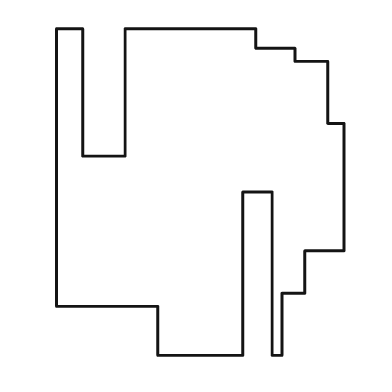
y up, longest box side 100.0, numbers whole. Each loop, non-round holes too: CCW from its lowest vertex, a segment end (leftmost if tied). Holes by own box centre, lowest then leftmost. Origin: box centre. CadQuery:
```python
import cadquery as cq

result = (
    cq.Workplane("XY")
    .moveTo(-13.0, -50.0)
    .lineTo(13.0, -50.0)
    .lineTo(13.0, 0.0)
    .lineTo(22.0, 0.0)
    .lineTo(22.0, -50.0)
    .lineTo(25.0, -50.0)
    .lineTo(25.0, -31.0)
    .lineTo(32.0, -31.0)
    .lineTo(32.0, -18.0)
    .lineTo(44.0, -18.0)
    .lineTo(44.0, 21.0)
    .lineTo(39.0, 21.0)
    .lineTo(39.0, 40.0)
    .lineTo(29.0, 40.0)
    .lineTo(29.0, 44.0)
    .lineTo(17.0, 44.0)
    .lineTo(17.0, 50.0)
    .lineTo(-23.0, 50.0)
    .lineTo(-23.0, 11.0)
    .lineTo(-36.0, 11.0)
    .lineTo(-36.0, 50.0)
    .lineTo(-44.0, 50.0)
    .lineTo(-44.0, -35.0)
    .lineTo(-13.0, -35.0)
    .close()
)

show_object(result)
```